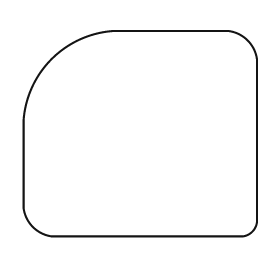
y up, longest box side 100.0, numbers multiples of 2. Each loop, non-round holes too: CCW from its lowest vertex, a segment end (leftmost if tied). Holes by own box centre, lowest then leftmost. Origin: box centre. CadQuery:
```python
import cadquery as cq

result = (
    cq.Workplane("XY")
    .moveTo(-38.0, -44.0)
    .lineTo(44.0, -44.0)
    .threePointArc((48.0, -42.0), (50.0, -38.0))
    .lineTo(50.0, 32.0)
    .threePointArc((46.0, 40.0), (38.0, 44.0))
    .lineTo(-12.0, 44.0)
    .threePointArc((-38.0, 32.0), (-50.0, 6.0))
    .lineTo(-50.0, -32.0)
    .threePointArc((-46.0, -40.0), (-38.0, -44.0))
    .close()
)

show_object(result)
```